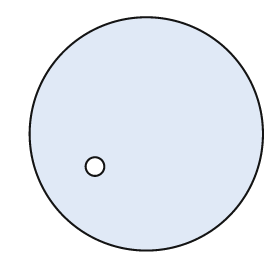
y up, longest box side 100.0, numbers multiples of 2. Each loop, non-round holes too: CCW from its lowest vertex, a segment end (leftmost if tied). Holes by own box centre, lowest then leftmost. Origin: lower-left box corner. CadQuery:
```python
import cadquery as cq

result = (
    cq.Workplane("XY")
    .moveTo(50.0, 50.0)
    .circle(50.0)
    .moveTo(28.0, 36.0)
    .circle(4.0)
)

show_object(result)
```